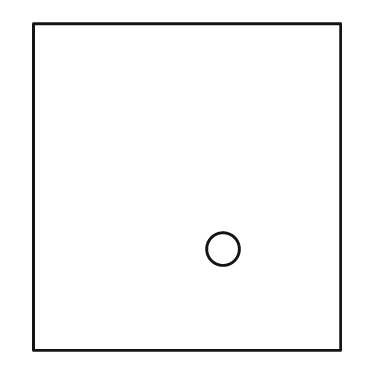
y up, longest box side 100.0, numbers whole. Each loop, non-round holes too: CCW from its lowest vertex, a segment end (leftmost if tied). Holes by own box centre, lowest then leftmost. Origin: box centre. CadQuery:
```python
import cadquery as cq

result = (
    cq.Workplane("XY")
    .moveTo(-47.0, -50.0)
    .lineTo(47.0, -50.0)
    .lineTo(47.0, 50.0)
    .lineTo(-47.0, 50.0)
    .close()
    .moveTo(11.0, -19.0)
    .circle(5.0)
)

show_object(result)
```